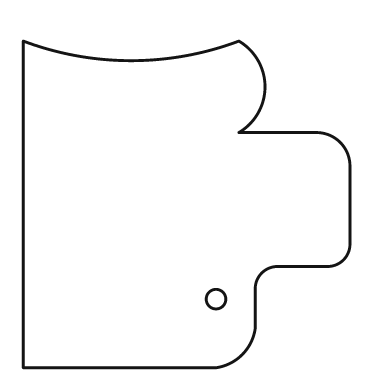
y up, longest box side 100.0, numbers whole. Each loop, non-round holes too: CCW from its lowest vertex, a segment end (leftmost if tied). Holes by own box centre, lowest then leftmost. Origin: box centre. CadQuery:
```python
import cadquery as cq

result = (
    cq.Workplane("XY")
    .moveTo(-50.0, -50.0)
    .lineTo(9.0, -50.0)
    .threePointArc((17.0, -46.0), (21.0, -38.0))
    .lineTo(21.0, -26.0)
    .threePointArc((23.0, -21.0), (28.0, -19.0))
    .lineTo(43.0, -19.0)
    .threePointArc((48.0, -17.0), (50.0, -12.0))
    .lineTo(50.0, 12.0)
    .threePointArc((47.0, 19.0), (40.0, 22.0))
    .lineTo(16.0, 22.0)
    .threePointArc((24.0, 36.0), (16.0, 50.0))
    .threePointArc((-17.0, 44.0), (-50.0, 50.0))
    .close()
    .moveTo(9.0, -29.0)
    .circle(3.0)
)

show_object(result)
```